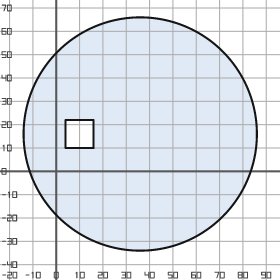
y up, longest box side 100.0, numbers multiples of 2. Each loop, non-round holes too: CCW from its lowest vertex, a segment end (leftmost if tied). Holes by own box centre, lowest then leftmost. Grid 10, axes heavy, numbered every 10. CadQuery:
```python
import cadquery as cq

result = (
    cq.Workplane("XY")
    .moveTo(36.0, 16.0)
    .circle(50.0)
    .moveTo(4.0, 10.0)
    .lineTo(16.0, 10.0)
    .lineTo(16.0, 22.0)
    .lineTo(4.0, 22.0)
    .close()
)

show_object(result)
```